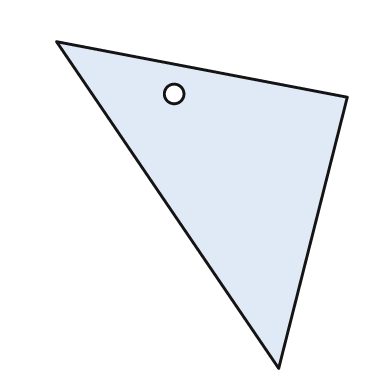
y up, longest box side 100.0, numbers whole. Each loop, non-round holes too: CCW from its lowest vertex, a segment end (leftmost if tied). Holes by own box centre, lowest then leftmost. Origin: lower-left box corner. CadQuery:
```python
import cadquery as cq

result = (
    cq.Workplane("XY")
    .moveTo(68.0, 0.0)
    .lineTo(89.0, 83.0)
    .lineTo(0.0, 100.0)
    .close()
    .moveTo(36.0, 84.0)
    .circle(3.0)
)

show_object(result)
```